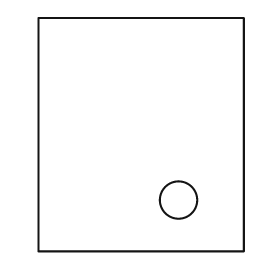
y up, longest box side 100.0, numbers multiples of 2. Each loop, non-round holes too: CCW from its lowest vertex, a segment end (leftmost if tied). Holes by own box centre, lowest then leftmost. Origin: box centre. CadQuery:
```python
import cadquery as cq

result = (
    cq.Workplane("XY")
    .moveTo(-44.0, -50.0)
    .lineTo(44.0, -50.0)
    .lineTo(44.0, 50.0)
    .lineTo(-44.0, 50.0)
    .close()
    .moveTo(16.0, -28.0)
    .circle(8.0)
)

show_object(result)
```